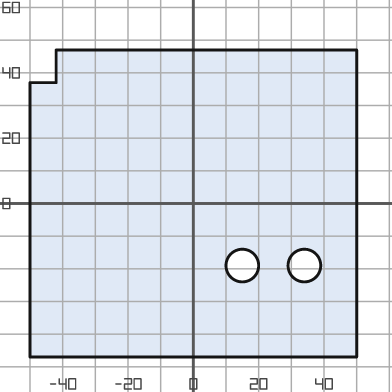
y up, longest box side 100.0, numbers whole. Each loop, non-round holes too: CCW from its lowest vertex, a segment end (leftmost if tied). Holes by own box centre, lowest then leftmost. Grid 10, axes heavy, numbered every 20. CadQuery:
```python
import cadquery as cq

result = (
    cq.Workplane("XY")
    .moveTo(-50.0, -47.0)
    .lineTo(50.0, -47.0)
    .lineTo(50.0, 47.0)
    .lineTo(-42.0, 47.0)
    .lineTo(-42.0, 37.0)
    .lineTo(-50.0, 37.0)
    .close()
    .moveTo(15.0, -19.0)
    .circle(5.0)
    .moveTo(34.0, -19.0)
    .circle(5.0)
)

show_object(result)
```